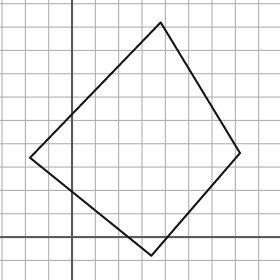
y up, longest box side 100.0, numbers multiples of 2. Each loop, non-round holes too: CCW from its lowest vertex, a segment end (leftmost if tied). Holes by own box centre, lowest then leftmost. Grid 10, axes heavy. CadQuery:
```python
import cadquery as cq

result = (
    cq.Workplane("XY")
    .moveTo(34.0, -8.0)
    .lineTo(72.0, 36.0)
    .lineTo(38.0, 92.0)
    .lineTo(-18.0, 34.0)
    .close()
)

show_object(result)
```